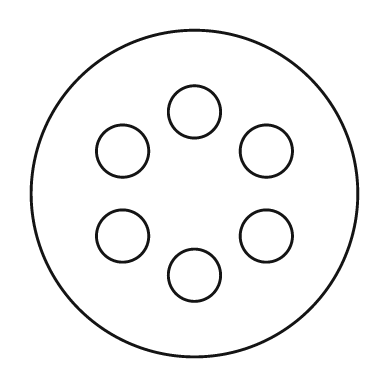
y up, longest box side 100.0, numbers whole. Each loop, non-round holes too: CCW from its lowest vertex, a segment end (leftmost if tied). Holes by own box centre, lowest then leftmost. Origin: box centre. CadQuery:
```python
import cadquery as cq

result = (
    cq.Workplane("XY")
    .moveTo(0.0, 0.0)
    .circle(50.0)
    .moveTo(0.0, -25.0)
    .circle(8.0)
    .moveTo(-22.0, -13.0)
    .circle(8.0)
    .moveTo(22.0, -13.0)
    .circle(8.0)
    .moveTo(-22.0, 13.0)
    .circle(8.0)
    .moveTo(22.0, 13.0)
    .circle(8.0)
    .moveTo(0.0, 25.0)
    .circle(8.0)
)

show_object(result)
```